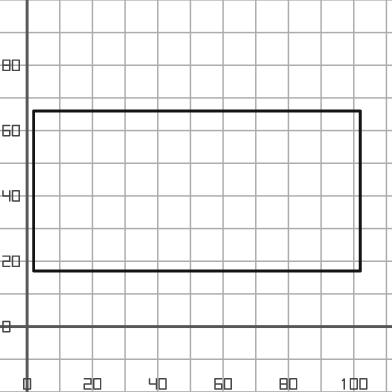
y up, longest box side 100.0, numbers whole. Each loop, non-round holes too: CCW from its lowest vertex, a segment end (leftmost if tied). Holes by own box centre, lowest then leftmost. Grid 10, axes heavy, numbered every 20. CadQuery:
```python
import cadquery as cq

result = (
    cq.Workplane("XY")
    .moveTo(2.0, 17.0)
    .lineTo(102.0, 17.0)
    .lineTo(102.0, 66.0)
    .lineTo(2.0, 66.0)
    .close()
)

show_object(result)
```